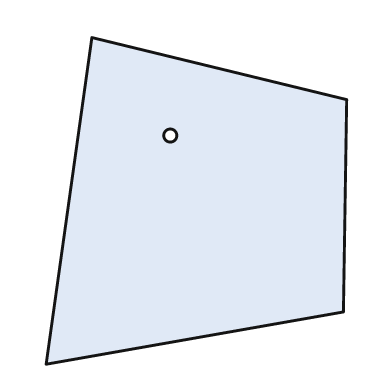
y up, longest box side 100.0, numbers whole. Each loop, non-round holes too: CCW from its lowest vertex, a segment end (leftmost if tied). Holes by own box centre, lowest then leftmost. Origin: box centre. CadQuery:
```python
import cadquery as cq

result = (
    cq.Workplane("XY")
    .moveTo(-46.0, -50.0)
    .lineTo(45.0, -34.0)
    .lineTo(46.0, 31.0)
    .lineTo(-32.0, 50.0)
    .close()
    .moveTo(-8.0, 20.0)
    .circle(2.0)
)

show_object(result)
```